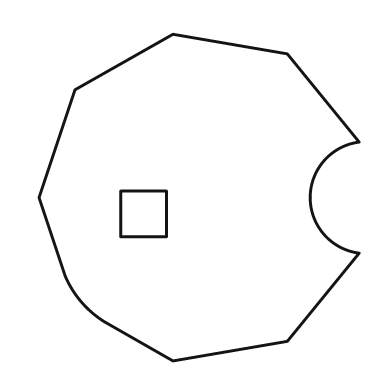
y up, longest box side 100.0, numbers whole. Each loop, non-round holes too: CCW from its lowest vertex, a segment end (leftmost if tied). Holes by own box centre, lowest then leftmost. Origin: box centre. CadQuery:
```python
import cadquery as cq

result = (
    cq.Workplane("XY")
    .moveTo(-8.0, -50.0)
    .lineTo(27.0, -44.0)
    .lineTo(49.0, -17.0)
    .threePointArc((34.0, 0.0), (49.0, 17.0))
    .lineTo(27.0, 44.0)
    .lineTo(-8.0, 50.0)
    .lineTo(-38.0, 33.0)
    .lineTo(-49.0, 0.0)
    .lineTo(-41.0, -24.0)
    .threePointArc((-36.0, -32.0), (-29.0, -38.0))
    .close()
    .moveTo(-24.0, -12.0)
    .lineTo(-10.0, -12.0)
    .lineTo(-10.0, 2.0)
    .lineTo(-24.0, 2.0)
    .close()
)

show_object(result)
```